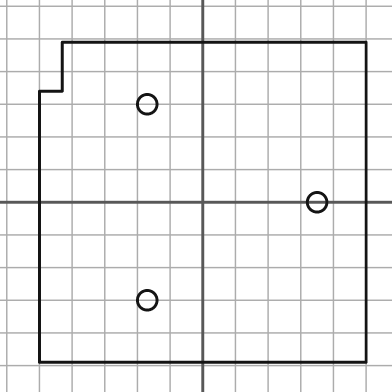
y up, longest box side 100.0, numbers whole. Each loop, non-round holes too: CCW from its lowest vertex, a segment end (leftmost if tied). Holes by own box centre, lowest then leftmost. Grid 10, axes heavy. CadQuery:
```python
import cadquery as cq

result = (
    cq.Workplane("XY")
    .moveTo(-50.0, -49.0)
    .lineTo(50.0, -49.0)
    .lineTo(50.0, 49.0)
    .lineTo(-43.0, 49.0)
    .lineTo(-43.0, 34.0)
    .lineTo(-50.0, 34.0)
    .close()
    .moveTo(-17.0, -30.0)
    .circle(3.0)
    .moveTo(35.0, 0.0)
    .circle(3.0)
    .moveTo(-17.0, 30.0)
    .circle(3.0)
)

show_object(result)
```